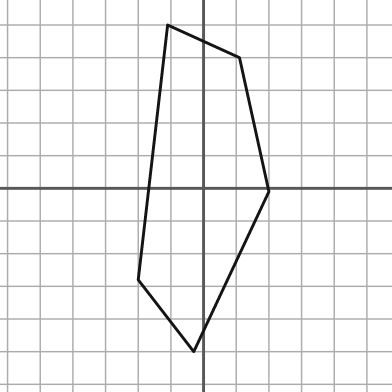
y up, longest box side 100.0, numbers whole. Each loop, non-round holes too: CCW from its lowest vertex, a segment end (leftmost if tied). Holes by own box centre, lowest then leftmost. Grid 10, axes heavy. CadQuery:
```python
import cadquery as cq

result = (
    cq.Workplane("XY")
    .moveTo(-3.0, -50.0)
    .lineTo(20.0, -1.0)
    .lineTo(11.0, 40.0)
    .lineTo(-11.0, 50.0)
    .lineTo(-20.0, -28.0)
    .close()
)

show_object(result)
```